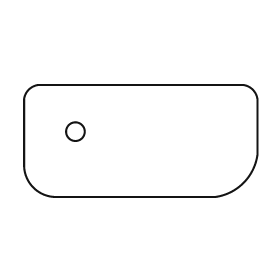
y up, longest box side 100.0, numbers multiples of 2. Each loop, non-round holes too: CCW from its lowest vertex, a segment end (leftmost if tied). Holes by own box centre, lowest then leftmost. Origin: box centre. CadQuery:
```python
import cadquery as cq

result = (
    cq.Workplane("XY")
    .moveTo(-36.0, -24.0)
    .lineTo(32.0, -24.0)
    .threePointArc((44.0, -18.0), (50.0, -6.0))
    .lineTo(50.0, 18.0)
    .threePointArc((48.0, 22.0), (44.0, 24.0))
    .lineTo(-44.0, 24.0)
    .threePointArc((-48.0, 22.0), (-50.0, 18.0))
    .lineTo(-50.0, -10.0)
    .threePointArc((-46.0, -20.0), (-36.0, -24.0))
    .close()
    .moveTo(-28.0, 4.0)
    .circle(4.0)
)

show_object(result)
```